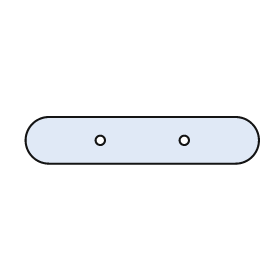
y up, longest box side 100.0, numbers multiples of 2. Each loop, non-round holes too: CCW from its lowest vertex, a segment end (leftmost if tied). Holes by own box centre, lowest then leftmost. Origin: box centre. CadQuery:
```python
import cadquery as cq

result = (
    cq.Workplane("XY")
    .moveTo(-40.0, -10.0)
    .lineTo(40.0, -10.0)
    .threePointArc((50.0, 0.0), (40.0, 10.0))
    .lineTo(-40.0, 10.0)
    .threePointArc((-50.0, 0.0), (-40.0, -10.0))
    .close()
    .moveTo(-18.0, 0.0)
    .circle(2.0)
    .moveTo(18.0, 0.0)
    .circle(2.0)
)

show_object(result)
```